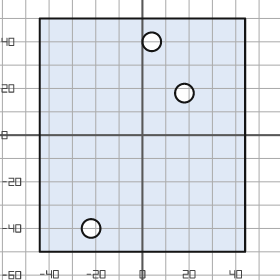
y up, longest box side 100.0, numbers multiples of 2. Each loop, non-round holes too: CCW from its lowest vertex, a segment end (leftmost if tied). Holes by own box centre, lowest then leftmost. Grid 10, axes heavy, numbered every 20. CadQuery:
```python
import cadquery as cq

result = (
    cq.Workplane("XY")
    .moveTo(-44.0, -50.0)
    .lineTo(44.0, -50.0)
    .lineTo(44.0, 50.0)
    .lineTo(-44.0, 50.0)
    .close()
    .moveTo(-22.0, -40.0)
    .circle(4.0)
    .moveTo(18.0, 18.0)
    .circle(4.0)
    .moveTo(4.0, 40.0)
    .circle(4.0)
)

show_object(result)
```